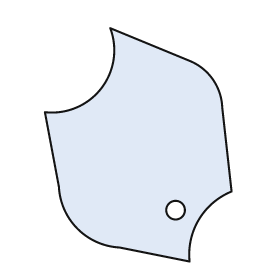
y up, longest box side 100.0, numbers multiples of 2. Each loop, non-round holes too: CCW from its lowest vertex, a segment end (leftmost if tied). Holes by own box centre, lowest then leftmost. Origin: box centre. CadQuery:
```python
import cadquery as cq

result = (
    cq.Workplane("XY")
    .moveTo(22.0, -50.0)
    .threePointArc((26.0, -32.0), (40.0, -20.0))
    .lineTo(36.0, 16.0)
    .threePointArc((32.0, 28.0), (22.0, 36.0))
    .lineTo(-12.0, 50.0)
    .threePointArc((-16.0, 24.0), (-40.0, 14.0))
    .lineTo(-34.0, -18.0)
    .threePointArc((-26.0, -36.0), (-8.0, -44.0))
    .close()
    .moveTo(16.0, -28.0)
    .circle(4.0)
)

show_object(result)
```